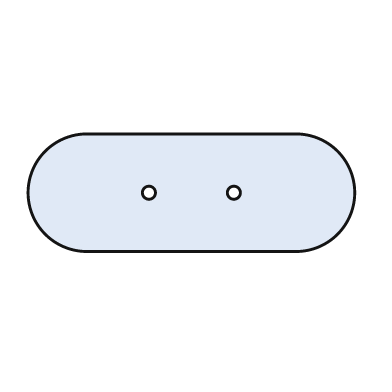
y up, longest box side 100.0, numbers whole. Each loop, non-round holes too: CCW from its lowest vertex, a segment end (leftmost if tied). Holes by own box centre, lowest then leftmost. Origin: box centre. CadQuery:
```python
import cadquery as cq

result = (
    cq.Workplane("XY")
    .moveTo(-32.0, -18.0)
    .lineTo(32.0, -18.0)
    .threePointArc((50.0, 0.0), (32.0, 18.0))
    .lineTo(-32.0, 18.0)
    .threePointArc((-50.0, 0.0), (-32.0, -18.0))
    .close()
    .moveTo(-13.0, 0.0)
    .circle(2.0)
    .moveTo(13.0, 0.0)
    .circle(2.0)
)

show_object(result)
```